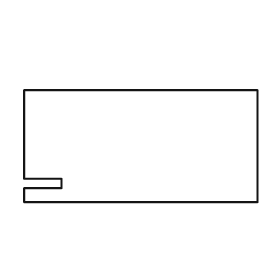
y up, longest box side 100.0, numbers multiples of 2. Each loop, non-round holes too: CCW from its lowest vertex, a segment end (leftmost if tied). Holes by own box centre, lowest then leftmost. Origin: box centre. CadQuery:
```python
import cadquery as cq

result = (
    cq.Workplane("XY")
    .moveTo(-50.0, -24.0)
    .lineTo(50.0, -24.0)
    .lineTo(50.0, 24.0)
    .lineTo(-50.0, 24.0)
    .lineTo(-50.0, -14.0)
    .lineTo(-34.0, -14.0)
    .lineTo(-34.0, -18.0)
    .lineTo(-50.0, -18.0)
    .close()
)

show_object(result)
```